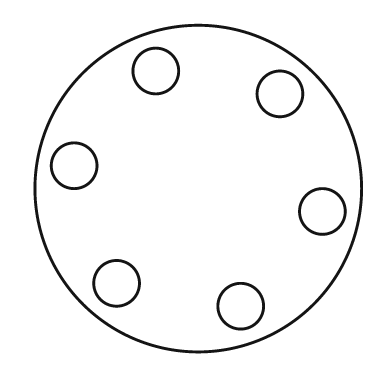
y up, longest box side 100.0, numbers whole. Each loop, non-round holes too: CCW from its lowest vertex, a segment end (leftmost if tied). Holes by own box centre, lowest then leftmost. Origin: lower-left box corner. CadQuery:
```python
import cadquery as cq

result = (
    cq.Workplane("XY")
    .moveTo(50.0, 50.0)
    .circle(50.0)
    .moveTo(63.0, 14.0)
    .circle(7.0)
    .moveTo(25.0, 21.0)
    .circle(7.0)
    .moveTo(88.0, 43.0)
    .circle(7.0)
    .moveTo(12.0, 57.0)
    .circle(7.0)
    .moveTo(75.0, 79.0)
    .circle(7.0)
    .moveTo(37.0, 86.0)
    .circle(7.0)
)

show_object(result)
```